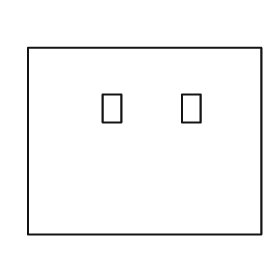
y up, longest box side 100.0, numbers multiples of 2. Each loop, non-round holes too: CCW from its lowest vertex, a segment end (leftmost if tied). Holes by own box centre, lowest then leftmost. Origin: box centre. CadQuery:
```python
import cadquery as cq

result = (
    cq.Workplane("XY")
    .moveTo(-50.0, -40.0)
    .lineTo(50.0, -40.0)
    .lineTo(50.0, 40.0)
    .lineTo(-50.0, 40.0)
    .close()
    .moveTo(-18.0, 8.0)
    .lineTo(-10.0, 8.0)
    .lineTo(-10.0, 20.0)
    .lineTo(-18.0, 20.0)
    .close()
    .moveTo(16.0, 8.0)
    .lineTo(24.0, 8.0)
    .lineTo(24.0, 20.0)
    .lineTo(16.0, 20.0)
    .close()
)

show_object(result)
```